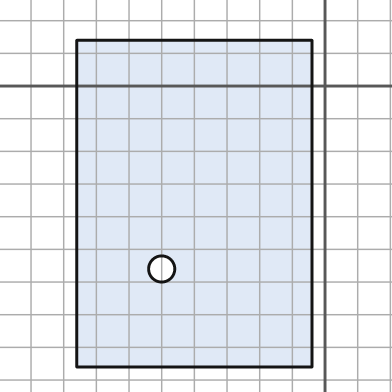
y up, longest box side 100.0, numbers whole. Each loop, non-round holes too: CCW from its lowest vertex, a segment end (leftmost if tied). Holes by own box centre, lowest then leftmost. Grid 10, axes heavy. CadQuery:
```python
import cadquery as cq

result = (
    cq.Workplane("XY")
    .moveTo(-76.0, -86.0)
    .lineTo(-4.0, -86.0)
    .lineTo(-4.0, 14.0)
    .lineTo(-76.0, 14.0)
    .close()
    .moveTo(-50.0, -56.0)
    .circle(4.0)
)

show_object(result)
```